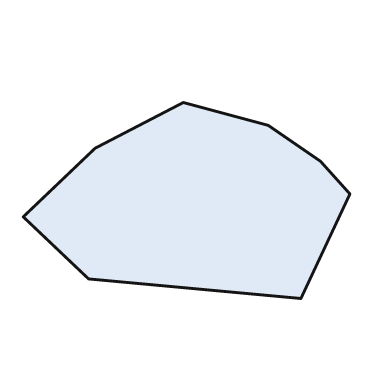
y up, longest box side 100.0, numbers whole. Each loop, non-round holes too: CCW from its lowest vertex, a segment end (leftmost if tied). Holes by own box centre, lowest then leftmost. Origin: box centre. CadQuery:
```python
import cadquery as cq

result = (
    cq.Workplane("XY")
    .moveTo(35.0, -30.0)
    .lineTo(50.0, 2.0)
    .lineTo(41.0, 12.0)
    .lineTo(25.0, 23.0)
    .lineTo(-1.0, 30.0)
    .lineTo(-28.0, 16.0)
    .lineTo(-50.0, -5.0)
    .lineTo(-30.0, -24.0)
    .close()
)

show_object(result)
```